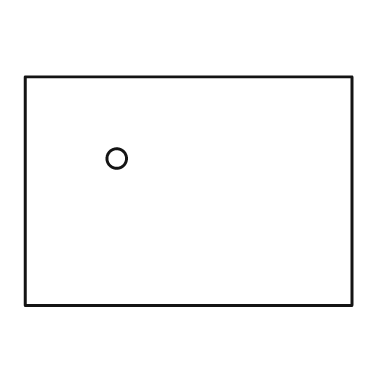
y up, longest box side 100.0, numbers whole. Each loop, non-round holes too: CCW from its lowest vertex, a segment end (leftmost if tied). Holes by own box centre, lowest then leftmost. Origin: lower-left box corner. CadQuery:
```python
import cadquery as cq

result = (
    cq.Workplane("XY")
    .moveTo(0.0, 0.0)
    .lineTo(100.0, 0.0)
    .lineTo(100.0, 70.0)
    .lineTo(0.0, 70.0)
    .close()
    .moveTo(28.0, 45.0)
    .circle(3.0)
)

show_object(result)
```